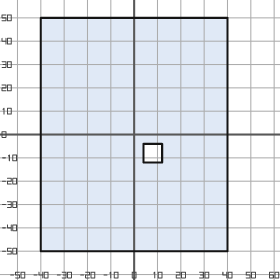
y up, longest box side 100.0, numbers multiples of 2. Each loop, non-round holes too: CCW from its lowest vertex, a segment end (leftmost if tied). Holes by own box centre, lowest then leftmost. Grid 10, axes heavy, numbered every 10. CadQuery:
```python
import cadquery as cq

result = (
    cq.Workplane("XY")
    .moveTo(-40.0, -50.0)
    .lineTo(40.0, -50.0)
    .lineTo(40.0, 50.0)
    .lineTo(-40.0, 50.0)
    .close()
    .moveTo(4.0, -12.0)
    .lineTo(12.0, -12.0)
    .lineTo(12.0, -4.0)
    .lineTo(4.0, -4.0)
    .close()
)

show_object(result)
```